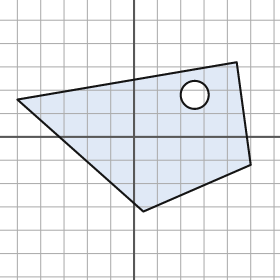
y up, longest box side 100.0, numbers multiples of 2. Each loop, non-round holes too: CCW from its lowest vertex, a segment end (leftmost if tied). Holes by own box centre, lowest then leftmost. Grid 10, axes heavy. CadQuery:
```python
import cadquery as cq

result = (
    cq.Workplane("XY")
    .moveTo(4.0, -32.0)
    .lineTo(50.0, -12.0)
    .lineTo(44.0, 32.0)
    .lineTo(-50.0, 16.0)
    .close()
    .moveTo(26.0, 18.0)
    .circle(6.0)
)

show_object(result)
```